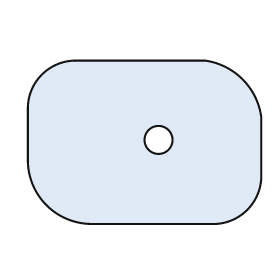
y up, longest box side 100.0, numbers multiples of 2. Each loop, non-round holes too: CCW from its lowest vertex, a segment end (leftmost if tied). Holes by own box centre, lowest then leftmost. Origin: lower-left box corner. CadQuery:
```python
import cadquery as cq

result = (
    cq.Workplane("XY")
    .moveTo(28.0, 0.0)
    .lineTo(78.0, 0.0)
    .threePointArc((94.0, 6.0), (100.0, 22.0))
    .lineTo(100.0, 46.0)
    .threePointArc((92.0, 62.0), (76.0, 70.0))
    .lineTo(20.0, 70.0)
    .threePointArc((6.0, 64.0), (0.0, 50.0))
    .lineTo(0.0, 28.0)
    .threePointArc((8.0, 8.0), (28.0, 0.0))
    .close()
    .moveTo(56.0, 36.0)
    .circle(6.0)
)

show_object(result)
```